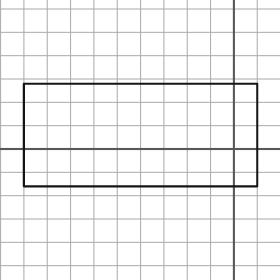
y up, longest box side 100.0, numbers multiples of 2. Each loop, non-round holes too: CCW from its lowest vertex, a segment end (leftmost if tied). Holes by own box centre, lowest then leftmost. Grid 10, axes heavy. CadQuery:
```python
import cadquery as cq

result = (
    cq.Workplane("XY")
    .moveTo(-90.0, -16.0)
    .lineTo(10.0, -16.0)
    .lineTo(10.0, 28.0)
    .lineTo(-90.0, 28.0)
    .close()
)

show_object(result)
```